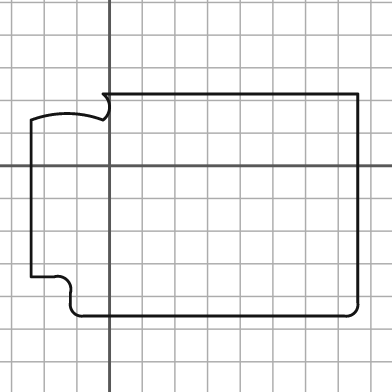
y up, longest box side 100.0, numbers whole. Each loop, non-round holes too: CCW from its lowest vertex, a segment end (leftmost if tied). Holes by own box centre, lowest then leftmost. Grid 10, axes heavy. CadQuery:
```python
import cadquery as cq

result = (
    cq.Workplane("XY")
    .moveTo(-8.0, -46.0)
    .lineTo(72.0, -46.0)
    .threePointArc((75.0, -45.0), (76.0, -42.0))
    .lineTo(76.0, 22.0)
    .lineTo(-2.0, 22.0)
    .threePointArc((0.0, 18.0), (-2.0, 14.0))
    .threePointArc((-13.0, 16.0), (-24.0, 14.0))
    .lineTo(-24.0, -34.0)
    .lineTo(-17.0, -34.0)
    .threePointArc((-13.0, -35.0), (-12.0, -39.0))
    .lineTo(-12.0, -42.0)
    .threePointArc((-11.0, -45.0), (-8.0, -46.0))
    .close()
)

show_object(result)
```